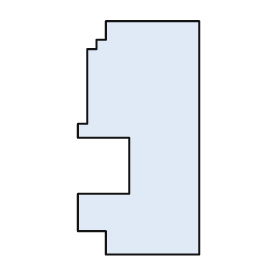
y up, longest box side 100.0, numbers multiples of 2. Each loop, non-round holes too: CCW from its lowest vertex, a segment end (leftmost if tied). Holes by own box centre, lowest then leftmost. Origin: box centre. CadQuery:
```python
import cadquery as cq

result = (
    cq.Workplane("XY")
    .moveTo(-14.0, -50.0)
    .lineTo(26.0, -50.0)
    .lineTo(26.0, 50.0)
    .lineTo(-14.0, 50.0)
    .lineTo(-14.0, 42.0)
    .lineTo(-18.0, 42.0)
    .lineTo(-18.0, 38.0)
    .lineTo(-22.0, 38.0)
    .lineTo(-22.0, 6.0)
    .lineTo(-26.0, 6.0)
    .lineTo(-26.0, 0.0)
    .lineTo(-4.0, 0.0)
    .lineTo(-4.0, -24.0)
    .lineTo(-26.0, -24.0)
    .lineTo(-26.0, -40.0)
    .lineTo(-14.0, -40.0)
    .close()
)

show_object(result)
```